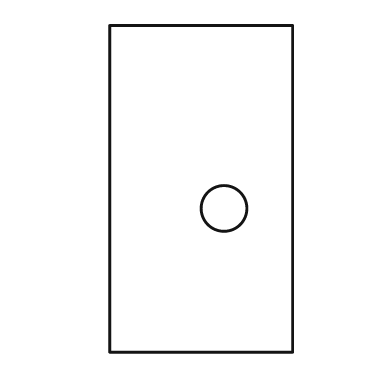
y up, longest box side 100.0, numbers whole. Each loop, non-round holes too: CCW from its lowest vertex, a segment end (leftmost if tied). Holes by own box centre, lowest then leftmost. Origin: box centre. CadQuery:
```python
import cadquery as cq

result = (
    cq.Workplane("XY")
    .moveTo(-28.0, -50.0)
    .lineTo(28.0, -50.0)
    .lineTo(28.0, 50.0)
    .lineTo(-28.0, 50.0)
    .close()
    .moveTo(7.0, -6.0)
    .circle(7.0)
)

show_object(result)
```